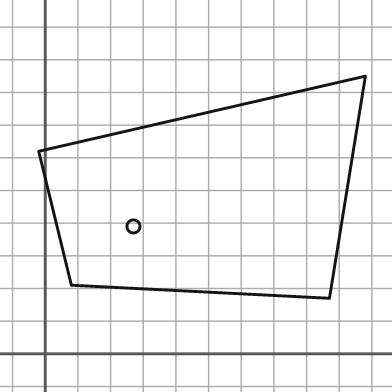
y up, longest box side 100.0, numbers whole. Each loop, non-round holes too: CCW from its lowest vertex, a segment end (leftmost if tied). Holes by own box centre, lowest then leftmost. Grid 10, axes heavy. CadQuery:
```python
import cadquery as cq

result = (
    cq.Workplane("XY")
    .moveTo(87.0, 17.0)
    .lineTo(98.0, 85.0)
    .lineTo(-2.0, 62.0)
    .lineTo(8.0, 21.0)
    .close()
    .moveTo(27.0, 39.0)
    .circle(2.0)
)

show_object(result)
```